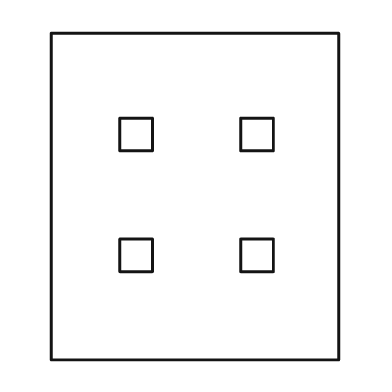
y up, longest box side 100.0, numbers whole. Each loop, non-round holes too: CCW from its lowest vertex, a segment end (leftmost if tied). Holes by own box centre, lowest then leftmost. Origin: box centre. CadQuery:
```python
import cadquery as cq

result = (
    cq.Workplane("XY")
    .moveTo(-44.0, -50.0)
    .lineTo(44.0, -50.0)
    .lineTo(44.0, 50.0)
    .lineTo(-44.0, 50.0)
    .close()
    .moveTo(-23.0, -23.0)
    .lineTo(-13.0, -23.0)
    .lineTo(-13.0, -13.0)
    .lineTo(-23.0, -13.0)
    .close()
    .moveTo(14.0, -23.0)
    .lineTo(24.0, -23.0)
    .lineTo(24.0, -13.0)
    .lineTo(14.0, -13.0)
    .close()
    .moveTo(-23.0, 14.0)
    .lineTo(-13.0, 14.0)
    .lineTo(-13.0, 24.0)
    .lineTo(-23.0, 24.0)
    .close()
    .moveTo(14.0, 14.0)
    .lineTo(24.0, 14.0)
    .lineTo(24.0, 24.0)
    .lineTo(14.0, 24.0)
    .close()
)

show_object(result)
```